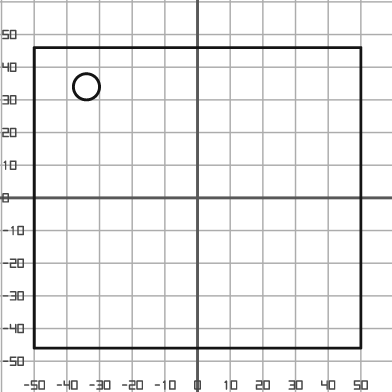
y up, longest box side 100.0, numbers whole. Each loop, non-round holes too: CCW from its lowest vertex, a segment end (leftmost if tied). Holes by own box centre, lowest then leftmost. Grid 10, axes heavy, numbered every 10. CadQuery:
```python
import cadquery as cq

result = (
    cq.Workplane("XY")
    .moveTo(-50.0, -46.0)
    .lineTo(50.0, -46.0)
    .lineTo(50.0, 46.0)
    .lineTo(-50.0, 46.0)
    .close()
    .moveTo(-34.0, 34.0)
    .circle(4.0)
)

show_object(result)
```